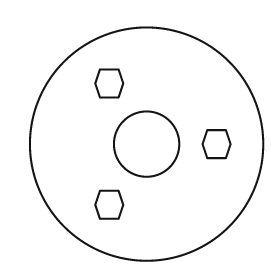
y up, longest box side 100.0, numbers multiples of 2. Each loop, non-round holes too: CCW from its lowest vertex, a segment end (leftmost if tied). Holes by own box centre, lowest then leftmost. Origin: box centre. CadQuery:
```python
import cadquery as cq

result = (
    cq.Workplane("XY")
    .moveTo(0.0, 0.0)
    .circle(50.0)
    .moveTo(-20.0, -32.0)
    .lineTo(-12.0, -32.0)
    .lineTo(-10.0, -26.0)
    .lineTo(-12.0, -20.0)
    .lineTo(-20.0, -20.0)
    .lineTo(-22.0, -26.0)
    .close()
    .moveTo(0.0, 0.0)
    .circle(14.0)
    .moveTo(26.0, -6.0)
    .lineTo(34.0, -6.0)
    .lineTo(36.0, 0.0)
    .lineTo(34.0, 6.0)
    .lineTo(26.0, 6.0)
    .lineTo(24.0, 0.0)
    .close()
    .moveTo(-20.0, 20.0)
    .lineTo(-12.0, 20.0)
    .lineTo(-10.0, 26.0)
    .lineTo(-12.0, 32.0)
    .lineTo(-20.0, 32.0)
    .lineTo(-22.0, 26.0)
    .close()
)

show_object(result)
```